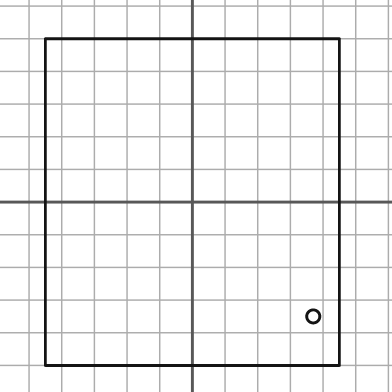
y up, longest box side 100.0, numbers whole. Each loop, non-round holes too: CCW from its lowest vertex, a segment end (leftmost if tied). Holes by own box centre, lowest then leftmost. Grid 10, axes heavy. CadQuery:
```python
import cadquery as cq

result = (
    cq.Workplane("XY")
    .moveTo(-45.0, -50.0)
    .lineTo(45.0, -50.0)
    .lineTo(45.0, 50.0)
    .lineTo(-45.0, 50.0)
    .close()
    .moveTo(37.0, -35.0)
    .circle(2.0)
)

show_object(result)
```